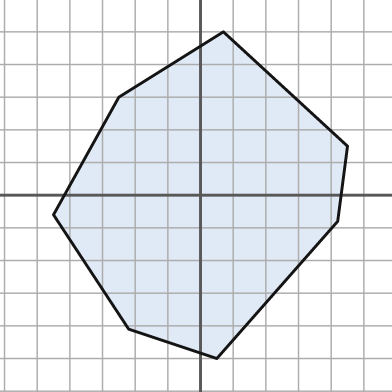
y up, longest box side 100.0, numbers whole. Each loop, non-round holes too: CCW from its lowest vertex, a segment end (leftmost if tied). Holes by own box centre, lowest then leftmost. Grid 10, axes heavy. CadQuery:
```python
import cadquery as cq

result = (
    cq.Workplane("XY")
    .moveTo(5.0, -50.0)
    .lineTo(42.0, -8.0)
    .lineTo(45.0, 15.0)
    .lineTo(7.0, 50.0)
    .lineTo(-25.0, 30.0)
    .lineTo(-45.0, -6.0)
    .lineTo(-22.0, -41.0)
    .close()
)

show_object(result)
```